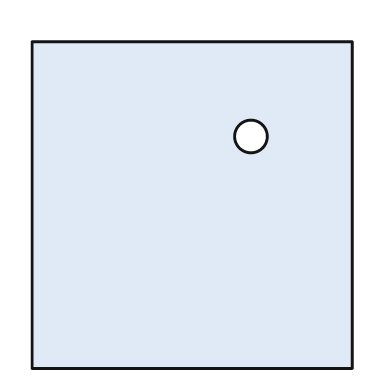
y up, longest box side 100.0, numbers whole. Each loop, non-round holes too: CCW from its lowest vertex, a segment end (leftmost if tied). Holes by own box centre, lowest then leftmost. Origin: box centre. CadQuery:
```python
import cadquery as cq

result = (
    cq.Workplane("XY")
    .moveTo(-49.0, -50.0)
    .lineTo(49.0, -50.0)
    .lineTo(49.0, 50.0)
    .lineTo(-49.0, 50.0)
    .close()
    .moveTo(18.0, 21.0)
    .circle(5.0)
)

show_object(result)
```